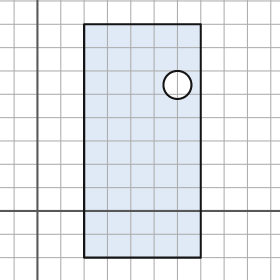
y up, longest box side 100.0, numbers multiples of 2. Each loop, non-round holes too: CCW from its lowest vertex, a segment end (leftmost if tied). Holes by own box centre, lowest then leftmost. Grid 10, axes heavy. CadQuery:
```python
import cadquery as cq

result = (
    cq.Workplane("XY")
    .moveTo(20.0, -20.0)
    .lineTo(70.0, -20.0)
    .lineTo(70.0, 80.0)
    .lineTo(20.0, 80.0)
    .close()
    .moveTo(60.0, 54.0)
    .circle(6.0)
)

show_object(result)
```